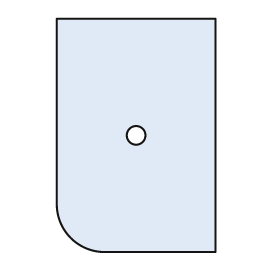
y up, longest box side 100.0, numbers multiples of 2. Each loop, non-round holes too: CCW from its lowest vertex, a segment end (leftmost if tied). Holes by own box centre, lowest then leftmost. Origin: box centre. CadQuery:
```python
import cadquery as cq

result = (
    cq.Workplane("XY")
    .moveTo(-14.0, -50.0)
    .lineTo(34.0, -50.0)
    .lineTo(34.0, 50.0)
    .lineTo(-34.0, 50.0)
    .lineTo(-34.0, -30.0)
    .threePointArc((-28.0, -44.0), (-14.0, -50.0))
    .close()
    .moveTo(0.0, 0.0)
    .circle(4.0)
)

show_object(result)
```